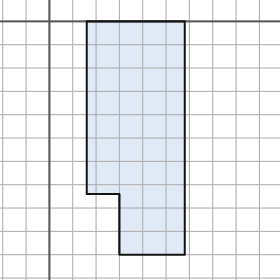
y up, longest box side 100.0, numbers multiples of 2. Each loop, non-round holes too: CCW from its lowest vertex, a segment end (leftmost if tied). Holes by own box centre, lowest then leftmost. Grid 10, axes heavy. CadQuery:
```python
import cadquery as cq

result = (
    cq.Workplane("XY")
    .moveTo(30.0, -100.0)
    .lineTo(58.0, -100.0)
    .lineTo(58.0, 0.0)
    .lineTo(16.0, 0.0)
    .lineTo(16.0, -74.0)
    .lineTo(30.0, -74.0)
    .close()
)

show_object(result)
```